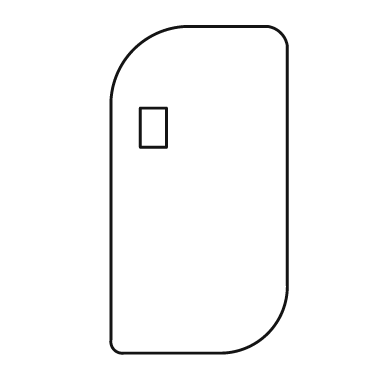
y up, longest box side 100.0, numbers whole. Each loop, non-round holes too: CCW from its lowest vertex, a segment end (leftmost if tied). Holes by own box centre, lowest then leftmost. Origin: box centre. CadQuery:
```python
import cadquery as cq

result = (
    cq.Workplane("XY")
    .moveTo(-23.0, -50.0)
    .lineTo(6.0, -50.0)
    .threePointArc((21.0, -44.0), (27.0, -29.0))
    .lineTo(27.0, 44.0)
    .threePointArc((25.0, 48.0), (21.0, 50.0))
    .lineTo(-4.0, 50.0)
    .threePointArc((-20.0, 43.0), (-27.0, 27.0))
    .lineTo(-27.0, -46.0)
    .threePointArc((-26.0, -49.0), (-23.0, -50.0))
    .close()
    .moveTo(-18.0, 13.0)
    .lineTo(-10.0, 13.0)
    .lineTo(-10.0, 25.0)
    .lineTo(-18.0, 25.0)
    .close()
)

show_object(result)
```